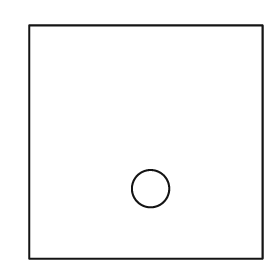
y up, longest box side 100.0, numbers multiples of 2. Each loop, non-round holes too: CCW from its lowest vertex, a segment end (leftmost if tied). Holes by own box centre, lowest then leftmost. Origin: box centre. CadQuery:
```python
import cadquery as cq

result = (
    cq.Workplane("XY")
    .moveTo(-50.0, -50.0)
    .lineTo(50.0, -50.0)
    .lineTo(50.0, 50.0)
    .lineTo(-50.0, 50.0)
    .close()
    .moveTo(2.0, -20.0)
    .circle(8.0)
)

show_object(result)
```